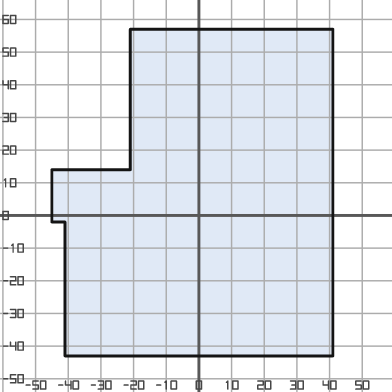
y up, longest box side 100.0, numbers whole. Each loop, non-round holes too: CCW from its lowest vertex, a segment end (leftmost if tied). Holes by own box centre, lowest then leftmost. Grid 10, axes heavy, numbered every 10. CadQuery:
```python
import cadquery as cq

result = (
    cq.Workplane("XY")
    .moveTo(-41.0, -43.0)
    .lineTo(41.0, -43.0)
    .lineTo(41.0, 57.0)
    .lineTo(-21.0, 57.0)
    .lineTo(-21.0, 14.0)
    .lineTo(-45.0, 14.0)
    .lineTo(-45.0, -2.0)
    .lineTo(-41.0, -2.0)
    .close()
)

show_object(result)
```